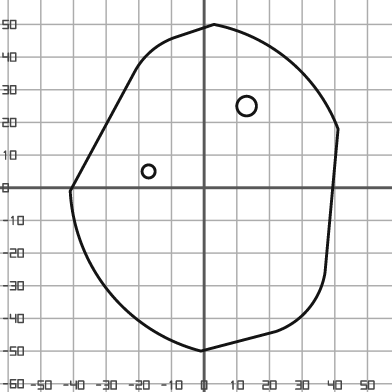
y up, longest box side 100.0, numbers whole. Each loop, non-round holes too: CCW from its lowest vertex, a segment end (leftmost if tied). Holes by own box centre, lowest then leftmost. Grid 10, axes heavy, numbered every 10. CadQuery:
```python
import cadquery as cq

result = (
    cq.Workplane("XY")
    .moveTo(-1.0, -50.0)
    .lineTo(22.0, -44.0)
    .threePointArc((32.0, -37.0), (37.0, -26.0))
    .lineTo(41.0, 18.0)
    .threePointArc((26.0, 39.0), (3.0, 50.0))
    .lineTo(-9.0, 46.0)
    .threePointArc((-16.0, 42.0), (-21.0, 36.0))
    .lineTo(-41.0, -1.0)
    .threePointArc((-29.0, -32.0), (-1.0, -50.0))
    .close()
    .moveTo(-17.0, 5.0)
    .circle(2.0)
    .moveTo(13.0, 25.0)
    .circle(3.0)
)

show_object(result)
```